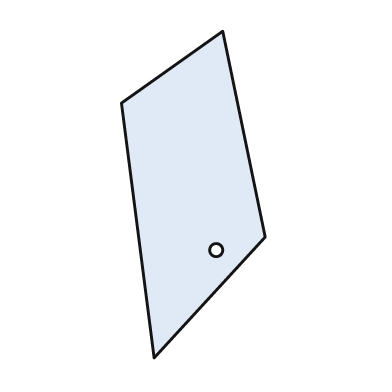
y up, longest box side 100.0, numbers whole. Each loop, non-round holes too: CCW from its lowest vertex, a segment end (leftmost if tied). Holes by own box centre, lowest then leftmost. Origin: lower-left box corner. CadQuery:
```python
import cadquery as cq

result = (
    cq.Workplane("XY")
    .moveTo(10.0, 0.0)
    .lineTo(44.0, 37.0)
    .lineTo(31.0, 100.0)
    .lineTo(0.0, 78.0)
    .close()
    .moveTo(29.0, 33.0)
    .circle(2.0)
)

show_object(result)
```